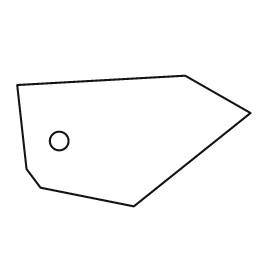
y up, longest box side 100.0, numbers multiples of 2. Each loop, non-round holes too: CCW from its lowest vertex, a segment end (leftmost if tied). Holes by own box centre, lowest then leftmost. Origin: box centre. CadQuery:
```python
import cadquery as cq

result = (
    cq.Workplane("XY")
    .moveTo(0.0, -28.0)
    .lineTo(50.0, 12.0)
    .lineTo(22.0, 28.0)
    .lineTo(-50.0, 24.0)
    .lineTo(-46.0, -12.0)
    .lineTo(-40.0, -20.0)
    .close()
    .moveTo(-32.0, 0.0)
    .circle(4.0)
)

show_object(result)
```